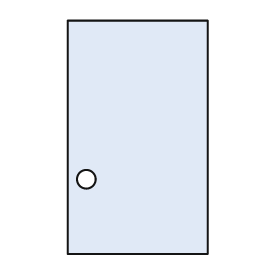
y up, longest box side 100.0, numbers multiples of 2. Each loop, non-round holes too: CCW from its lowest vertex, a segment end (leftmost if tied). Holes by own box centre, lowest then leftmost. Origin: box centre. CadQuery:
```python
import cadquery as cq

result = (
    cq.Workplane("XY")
    .moveTo(-30.0, -50.0)
    .lineTo(30.0, -50.0)
    .lineTo(30.0, 50.0)
    .lineTo(-30.0, 50.0)
    .close()
    .moveTo(-22.0, -18.0)
    .circle(4.0)
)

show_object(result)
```